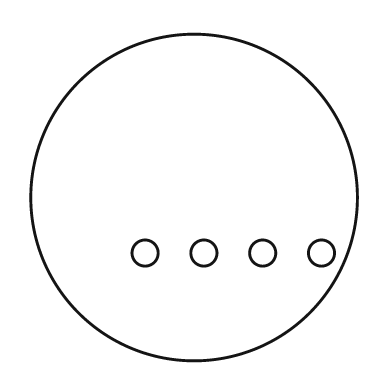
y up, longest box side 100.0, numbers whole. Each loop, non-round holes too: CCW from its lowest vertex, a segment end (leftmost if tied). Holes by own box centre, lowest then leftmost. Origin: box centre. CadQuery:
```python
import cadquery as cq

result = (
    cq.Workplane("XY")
    .moveTo(0.0, 0.0)
    .circle(50.0)
    .moveTo(-15.0, -17.0)
    .circle(4.0)
    .moveTo(3.0, -17.0)
    .circle(4.0)
    .moveTo(21.0, -17.0)
    .circle(4.0)
    .moveTo(39.0, -17.0)
    .circle(4.0)
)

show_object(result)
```